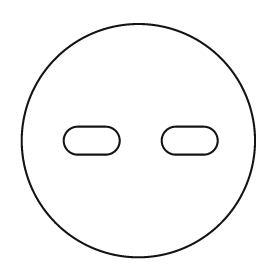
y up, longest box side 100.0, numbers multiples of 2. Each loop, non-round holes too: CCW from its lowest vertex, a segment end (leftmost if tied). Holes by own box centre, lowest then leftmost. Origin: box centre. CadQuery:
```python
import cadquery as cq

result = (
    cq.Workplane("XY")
    .moveTo(0.0, 0.0)
    .circle(50.0)
    .moveTo(-26.0, -6.0)
    .lineTo(-14.0, -6.0)
    .threePointArc((-8.0, 0.0), (-14.0, 6.0))
    .lineTo(-26.0, 6.0)
    .threePointArc((-32.0, 0.0), (-26.0, -6.0))
    .close()
    .moveTo(16.0, -6.0)
    .lineTo(28.0, -6.0)
    .threePointArc((34.0, 0.0), (28.0, 6.0))
    .lineTo(16.0, 6.0)
    .threePointArc((10.0, 0.0), (16.0, -6.0))
    .close()
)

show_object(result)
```